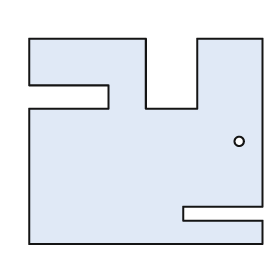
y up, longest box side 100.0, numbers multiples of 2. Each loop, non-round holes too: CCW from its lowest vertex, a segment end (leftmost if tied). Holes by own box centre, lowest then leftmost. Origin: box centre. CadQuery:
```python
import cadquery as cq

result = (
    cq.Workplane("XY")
    .moveTo(-50.0, -44.0)
    .lineTo(50.0, -44.0)
    .lineTo(50.0, -34.0)
    .lineTo(16.0, -34.0)
    .lineTo(16.0, -28.0)
    .lineTo(50.0, -28.0)
    .lineTo(50.0, 44.0)
    .lineTo(22.0, 44.0)
    .lineTo(22.0, 14.0)
    .lineTo(0.0, 14.0)
    .lineTo(0.0, 44.0)
    .lineTo(-50.0, 44.0)
    .lineTo(-50.0, 24.0)
    .lineTo(-16.0, 24.0)
    .lineTo(-16.0, 14.0)
    .lineTo(-50.0, 14.0)
    .close()
    .moveTo(40.0, 0.0)
    .circle(2.0)
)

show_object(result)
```